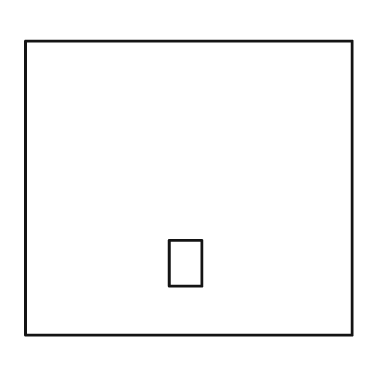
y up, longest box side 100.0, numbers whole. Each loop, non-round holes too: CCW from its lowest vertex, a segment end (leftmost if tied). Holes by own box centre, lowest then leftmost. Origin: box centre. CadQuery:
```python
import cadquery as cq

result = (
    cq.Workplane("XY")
    .moveTo(-50.0, -45.0)
    .lineTo(50.0, -45.0)
    .lineTo(50.0, 45.0)
    .lineTo(-50.0, 45.0)
    .close()
    .moveTo(-6.0, -30.0)
    .lineTo(4.0, -30.0)
    .lineTo(4.0, -16.0)
    .lineTo(-6.0, -16.0)
    .close()
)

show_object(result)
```